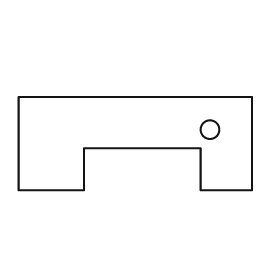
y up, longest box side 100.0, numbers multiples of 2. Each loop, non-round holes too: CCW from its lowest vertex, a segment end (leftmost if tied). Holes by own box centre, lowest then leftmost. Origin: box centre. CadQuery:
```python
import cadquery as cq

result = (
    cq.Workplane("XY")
    .moveTo(-50.0, -20.0)
    .lineTo(-22.0, -20.0)
    .lineTo(-22.0, -2.0)
    .lineTo(28.0, -2.0)
    .lineTo(28.0, -20.0)
    .lineTo(50.0, -20.0)
    .lineTo(50.0, 20.0)
    .lineTo(-50.0, 20.0)
    .close()
    .moveTo(32.0, 6.0)
    .circle(4.0)
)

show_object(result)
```